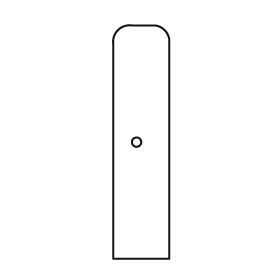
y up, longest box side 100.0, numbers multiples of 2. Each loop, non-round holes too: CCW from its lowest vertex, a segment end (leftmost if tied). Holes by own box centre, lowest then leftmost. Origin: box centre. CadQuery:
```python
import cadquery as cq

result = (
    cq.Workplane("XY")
    .moveTo(-12.0, -50.0)
    .lineTo(12.0, -50.0)
    .lineTo(12.0, 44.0)
    .threePointArc((10.0, 48.0), (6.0, 50.0))
    .lineTo(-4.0, 50.0)
    .threePointArc((-10.0, 48.0), (-12.0, 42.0))
    .close()
    .moveTo(-2.0, 0.0)
    .circle(2.0)
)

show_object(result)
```